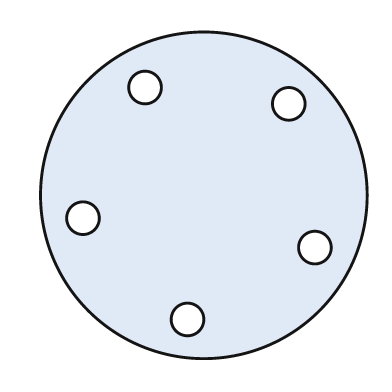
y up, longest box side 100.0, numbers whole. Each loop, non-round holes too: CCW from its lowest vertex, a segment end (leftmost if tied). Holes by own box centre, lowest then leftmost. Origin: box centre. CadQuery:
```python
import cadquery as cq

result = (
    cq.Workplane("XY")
    .moveTo(0.0, 0.0)
    .circle(50.0)
    .moveTo(-5.0, -38.0)
    .circle(5.0)
    .moveTo(34.0, -16.0)
    .circle(5.0)
    .moveTo(-37.0, -7.0)
    .circle(5.0)
    .moveTo(26.0, 28.0)
    .circle(5.0)
    .moveTo(-18.0, 33.0)
    .circle(5.0)
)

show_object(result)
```